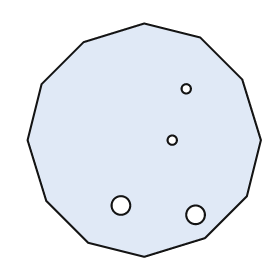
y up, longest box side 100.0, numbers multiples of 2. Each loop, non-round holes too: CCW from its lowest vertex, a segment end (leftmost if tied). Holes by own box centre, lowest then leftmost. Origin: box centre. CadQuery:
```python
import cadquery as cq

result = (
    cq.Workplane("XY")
    .moveTo(0.0, -50.0)
    .lineTo(26.0, -42.0)
    .lineTo(44.0, -24.0)
    .lineTo(50.0, 0.0)
    .lineTo(42.0, 26.0)
    .lineTo(24.0, 44.0)
    .lineTo(0.0, 50.0)
    .lineTo(-26.0, 42.0)
    .lineTo(-44.0, 24.0)
    .lineTo(-50.0, 0.0)
    .lineTo(-42.0, -26.0)
    .lineTo(-24.0, -44.0)
    .close()
    .moveTo(22.0, -32.0)
    .circle(4.0)
    .moveTo(-10.0, -28.0)
    .circle(4.0)
    .moveTo(12.0, 0.0)
    .circle(2.0)
    .moveTo(18.0, 22.0)
    .circle(2.0)
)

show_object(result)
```